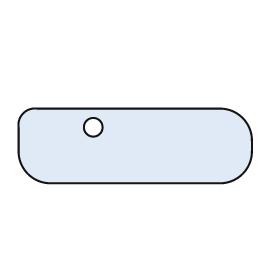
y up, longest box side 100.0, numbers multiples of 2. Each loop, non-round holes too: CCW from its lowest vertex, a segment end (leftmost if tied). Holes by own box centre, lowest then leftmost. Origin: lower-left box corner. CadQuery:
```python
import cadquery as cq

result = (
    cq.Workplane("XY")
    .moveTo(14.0, 0.0)
    .lineTo(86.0, 0.0)
    .threePointArc((96.0, 4.0), (100.0, 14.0))
    .lineTo(100.0, 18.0)
    .threePointArc((96.0, 28.0), (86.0, 32.0))
    .lineTo(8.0, 32.0)
    .threePointArc((2.0, 30.0), (0.0, 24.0))
    .lineTo(0.0, 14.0)
    .threePointArc((4.0, 4.0), (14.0, 0.0))
    .close()
    .moveTo(32.0, 24.0)
    .circle(4.0)
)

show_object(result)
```